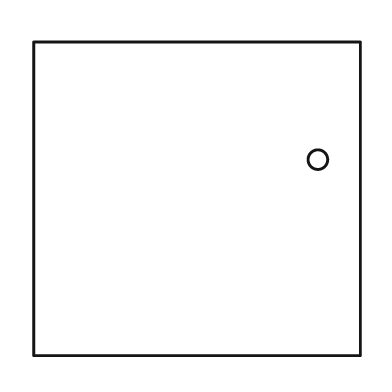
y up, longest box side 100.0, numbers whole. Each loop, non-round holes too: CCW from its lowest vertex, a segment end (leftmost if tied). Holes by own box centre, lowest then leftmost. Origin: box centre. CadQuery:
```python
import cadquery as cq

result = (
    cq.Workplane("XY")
    .moveTo(-50.0, -48.0)
    .lineTo(50.0, -48.0)
    .lineTo(50.0, 48.0)
    .lineTo(-50.0, 48.0)
    .close()
    .moveTo(37.0, 12.0)
    .circle(3.0)
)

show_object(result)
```